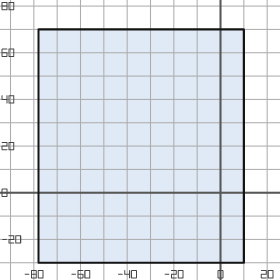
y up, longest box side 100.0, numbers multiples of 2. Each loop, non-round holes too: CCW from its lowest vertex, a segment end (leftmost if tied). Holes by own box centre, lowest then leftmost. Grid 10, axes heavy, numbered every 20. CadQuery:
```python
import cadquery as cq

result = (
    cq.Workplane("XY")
    .moveTo(-78.0, -30.0)
    .lineTo(10.0, -30.0)
    .lineTo(10.0, 70.0)
    .lineTo(-78.0, 70.0)
    .close()
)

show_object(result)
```